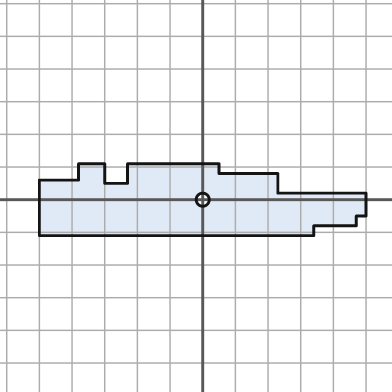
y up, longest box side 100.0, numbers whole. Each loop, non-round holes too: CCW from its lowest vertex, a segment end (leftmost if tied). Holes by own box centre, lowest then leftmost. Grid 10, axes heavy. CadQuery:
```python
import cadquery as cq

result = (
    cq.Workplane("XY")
    .moveTo(-50.0, -11.0)
    .lineTo(34.0, -11.0)
    .lineTo(34.0, -8.0)
    .lineTo(47.0, -8.0)
    .lineTo(47.0, -5.0)
    .lineTo(50.0, -5.0)
    .lineTo(50.0, 2.0)
    .lineTo(23.0, 2.0)
    .lineTo(23.0, 8.0)
    .lineTo(5.0, 8.0)
    .lineTo(5.0, 11.0)
    .lineTo(-23.0, 11.0)
    .lineTo(-23.0, 5.0)
    .lineTo(-30.0, 5.0)
    .lineTo(-30.0, 11.0)
    .lineTo(-38.0, 11.0)
    .lineTo(-38.0, 6.0)
    .lineTo(-50.0, 6.0)
    .close()
    .moveTo(0.0, 0.0)
    .circle(2.0)
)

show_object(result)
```